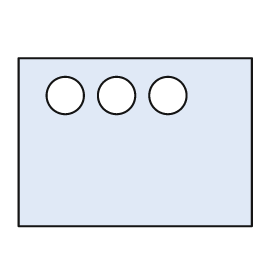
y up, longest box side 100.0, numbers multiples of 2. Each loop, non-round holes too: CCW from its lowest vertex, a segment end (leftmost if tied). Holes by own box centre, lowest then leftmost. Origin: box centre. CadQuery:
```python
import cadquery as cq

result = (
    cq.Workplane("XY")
    .moveTo(-50.0, -36.0)
    .lineTo(50.0, -36.0)
    .lineTo(50.0, 36.0)
    .lineTo(-50.0, 36.0)
    .close()
    .moveTo(-30.0, 20.0)
    .circle(8.0)
    .moveTo(-8.0, 20.0)
    .circle(8.0)
    .moveTo(14.0, 20.0)
    .circle(8.0)
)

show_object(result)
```